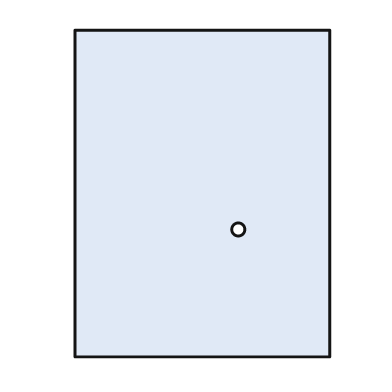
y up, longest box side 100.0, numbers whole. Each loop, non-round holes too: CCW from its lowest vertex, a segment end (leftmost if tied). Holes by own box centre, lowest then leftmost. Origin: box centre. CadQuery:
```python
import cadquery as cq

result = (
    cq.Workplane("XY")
    .moveTo(-39.0, -50.0)
    .lineTo(39.0, -50.0)
    .lineTo(39.0, 50.0)
    .lineTo(-39.0, 50.0)
    .close()
    .moveTo(11.0, -11.0)
    .circle(2.0)
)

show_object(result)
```